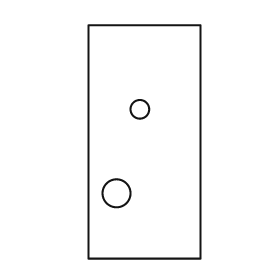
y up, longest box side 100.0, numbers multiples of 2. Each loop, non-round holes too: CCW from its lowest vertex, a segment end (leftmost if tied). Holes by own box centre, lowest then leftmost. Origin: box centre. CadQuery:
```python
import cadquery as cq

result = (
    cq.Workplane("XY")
    .moveTo(-24.0, -50.0)
    .lineTo(24.0, -50.0)
    .lineTo(24.0, 50.0)
    .lineTo(-24.0, 50.0)
    .close()
    .moveTo(-12.0, -22.0)
    .circle(6.0)
    .moveTo(-2.0, 14.0)
    .circle(4.0)
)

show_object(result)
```